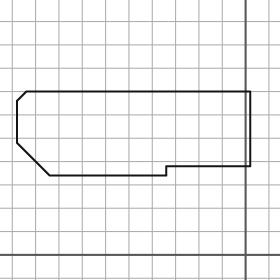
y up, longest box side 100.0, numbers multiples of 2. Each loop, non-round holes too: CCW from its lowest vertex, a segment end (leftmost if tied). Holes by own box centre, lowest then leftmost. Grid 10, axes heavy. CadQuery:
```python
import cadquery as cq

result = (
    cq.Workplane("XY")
    .moveTo(-84.0, 34.0)
    .lineTo(-34.0, 34.0)
    .lineTo(-34.0, 38.0)
    .lineTo(2.0, 38.0)
    .lineTo(2.0, 70.0)
    .lineTo(-94.0, 70.0)
    .lineTo(-98.0, 66.0)
    .lineTo(-98.0, 48.0)
    .close()
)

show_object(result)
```